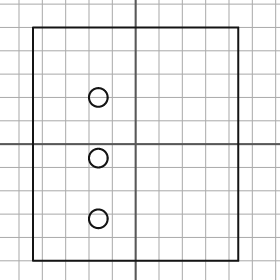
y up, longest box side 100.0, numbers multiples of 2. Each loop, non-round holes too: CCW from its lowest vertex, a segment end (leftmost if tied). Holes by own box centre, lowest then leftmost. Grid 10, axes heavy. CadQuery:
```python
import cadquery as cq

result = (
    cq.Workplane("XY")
    .moveTo(-44.0, -50.0)
    .lineTo(44.0, -50.0)
    .lineTo(44.0, 50.0)
    .lineTo(-44.0, 50.0)
    .close()
    .moveTo(-16.0, -32.0)
    .circle(4.0)
    .moveTo(-16.0, -6.0)
    .circle(4.0)
    .moveTo(-16.0, 20.0)
    .circle(4.0)
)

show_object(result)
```